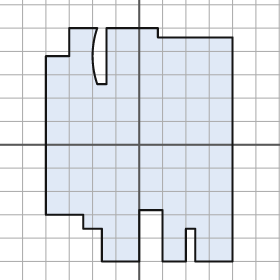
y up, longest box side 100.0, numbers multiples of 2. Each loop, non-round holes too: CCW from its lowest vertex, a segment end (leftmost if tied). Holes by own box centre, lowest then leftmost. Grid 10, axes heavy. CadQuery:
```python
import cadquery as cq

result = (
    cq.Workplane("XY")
    .moveTo(-16.0, -50.0)
    .lineTo(0.0, -50.0)
    .lineTo(0.0, -28.0)
    .lineTo(10.0, -28.0)
    .lineTo(10.0, -50.0)
    .lineTo(20.0, -50.0)
    .lineTo(20.0, -36.0)
    .lineTo(24.0, -36.0)
    .lineTo(24.0, -50.0)
    .lineTo(40.0, -50.0)
    .lineTo(40.0, 46.0)
    .lineTo(8.0, 46.0)
    .lineTo(8.0, 50.0)
    .lineTo(-14.0, 50.0)
    .lineTo(-14.0, 26.0)
    .lineTo(-18.0, 26.0)
    .threePointArc((-20.0, 38.0), (-18.0, 50.0))
    .lineTo(-30.0, 50.0)
    .lineTo(-30.0, 38.0)
    .lineTo(-40.0, 38.0)
    .lineTo(-40.0, -30.0)
    .lineTo(-24.0, -30.0)
    .lineTo(-24.0, -36.0)
    .lineTo(-16.0, -36.0)
    .close()
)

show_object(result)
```